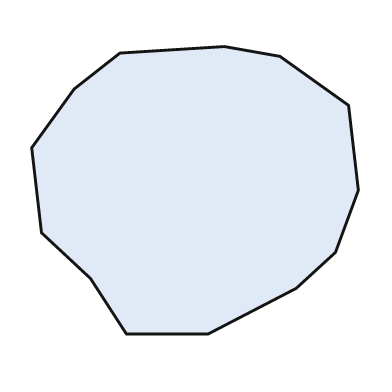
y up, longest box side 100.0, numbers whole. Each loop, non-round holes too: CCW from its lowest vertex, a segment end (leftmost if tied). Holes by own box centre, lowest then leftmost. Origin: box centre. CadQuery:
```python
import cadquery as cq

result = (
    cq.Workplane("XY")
    .moveTo(-21.0, -44.0)
    .lineTo(4.0, -44.0)
    .lineTo(31.0, -30.0)
    .lineTo(43.0, -19.0)
    .lineTo(50.0, 0.0)
    .lineTo(47.0, 26.0)
    .lineTo(26.0, 41.0)
    .lineTo(9.0, 44.0)
    .lineTo(-23.0, 42.0)
    .lineTo(-37.0, 31.0)
    .lineTo(-50.0, 13.0)
    .lineTo(-47.0, -13.0)
    .lineTo(-32.0, -27.0)
    .close()
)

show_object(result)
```